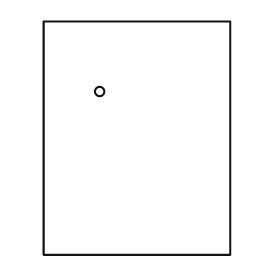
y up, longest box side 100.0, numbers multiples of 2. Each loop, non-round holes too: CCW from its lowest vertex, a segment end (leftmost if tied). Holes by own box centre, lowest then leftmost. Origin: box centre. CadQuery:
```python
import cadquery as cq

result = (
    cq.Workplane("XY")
    .moveTo(-40.0, -50.0)
    .lineTo(40.0, -50.0)
    .lineTo(40.0, 50.0)
    .lineTo(-40.0, 50.0)
    .close()
    .moveTo(-16.0, 20.0)
    .circle(2.0)
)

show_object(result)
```